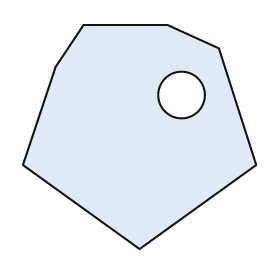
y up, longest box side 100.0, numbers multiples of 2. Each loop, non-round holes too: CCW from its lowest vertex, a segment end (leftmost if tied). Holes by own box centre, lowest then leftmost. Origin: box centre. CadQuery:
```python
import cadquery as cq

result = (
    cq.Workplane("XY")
    .moveTo(0.0, -48.0)
    .lineTo(50.0, -12.0)
    .lineTo(34.0, 38.0)
    .lineTo(12.0, 48.0)
    .lineTo(-24.0, 48.0)
    .lineTo(-36.0, 30.0)
    .lineTo(-50.0, -12.0)
    .close()
    .moveTo(18.0, 18.0)
    .circle(10.0)
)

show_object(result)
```